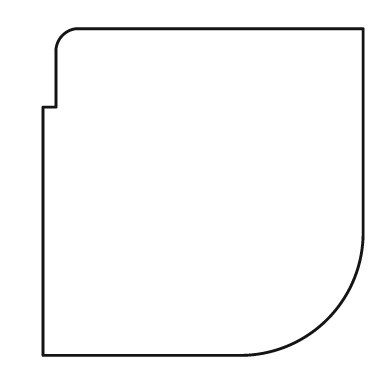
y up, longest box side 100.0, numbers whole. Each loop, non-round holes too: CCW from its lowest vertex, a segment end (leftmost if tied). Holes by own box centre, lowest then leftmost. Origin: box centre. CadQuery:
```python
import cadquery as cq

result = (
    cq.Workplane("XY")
    .moveTo(-49.0, -50.0)
    .lineTo(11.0, -50.0)
    .threePointArc((38.0, -39.0), (49.0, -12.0))
    .lineTo(49.0, 50.0)
    .lineTo(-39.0, 50.0)
    .threePointArc((-43.0, 48.0), (-45.0, 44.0))
    .lineTo(-45.0, 26.0)
    .lineTo(-49.0, 26.0)
    .close()
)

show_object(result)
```